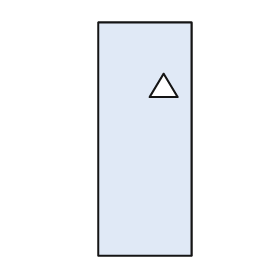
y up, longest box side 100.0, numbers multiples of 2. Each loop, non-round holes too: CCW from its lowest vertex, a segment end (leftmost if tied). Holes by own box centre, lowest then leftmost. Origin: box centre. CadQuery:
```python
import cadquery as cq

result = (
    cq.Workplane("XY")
    .moveTo(-20.0, -50.0)
    .lineTo(20.0, -50.0)
    .lineTo(20.0, 50.0)
    .lineTo(-20.0, 50.0)
    .close()
    .moveTo(2.0, 18.0)
    .lineTo(14.0, 18.0)
    .lineTo(8.0, 28.0)
    .close()
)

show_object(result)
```